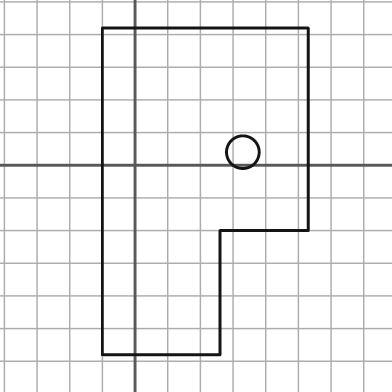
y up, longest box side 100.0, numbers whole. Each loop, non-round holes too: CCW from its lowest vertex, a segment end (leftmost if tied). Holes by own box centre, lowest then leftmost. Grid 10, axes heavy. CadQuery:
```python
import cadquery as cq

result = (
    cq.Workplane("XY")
    .moveTo(-10.0, -58.0)
    .lineTo(26.0, -58.0)
    .lineTo(26.0, -20.0)
    .lineTo(53.0, -20.0)
    .lineTo(53.0, 42.0)
    .lineTo(-10.0, 42.0)
    .close()
    .moveTo(33.0, 4.0)
    .circle(5.0)
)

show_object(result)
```